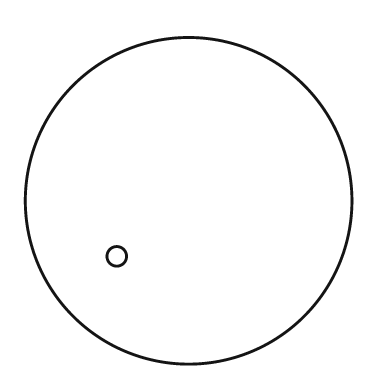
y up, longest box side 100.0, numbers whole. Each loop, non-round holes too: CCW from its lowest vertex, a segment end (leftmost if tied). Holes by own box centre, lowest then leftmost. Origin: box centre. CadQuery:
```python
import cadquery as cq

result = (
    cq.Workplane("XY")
    .moveTo(0.0, 0.0)
    .circle(50.0)
    .moveTo(-22.0, -17.0)
    .circle(3.0)
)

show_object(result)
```